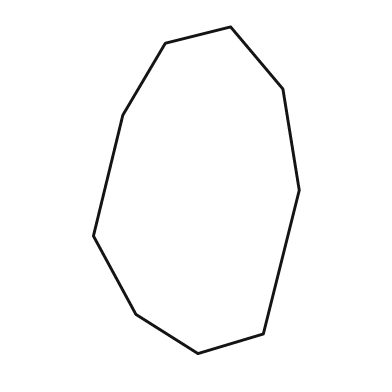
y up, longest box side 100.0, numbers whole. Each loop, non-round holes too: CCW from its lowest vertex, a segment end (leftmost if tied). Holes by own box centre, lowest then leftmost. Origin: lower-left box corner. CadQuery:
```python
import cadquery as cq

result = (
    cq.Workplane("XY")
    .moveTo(32.0, 0.0)
    .lineTo(52.0, 6.0)
    .lineTo(63.0, 50.0)
    .lineTo(58.0, 81.0)
    .lineTo(42.0, 100.0)
    .lineTo(22.0, 95.0)
    .lineTo(9.0, 73.0)
    .lineTo(0.0, 36.0)
    .lineTo(13.0, 12.0)
    .close()
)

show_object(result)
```